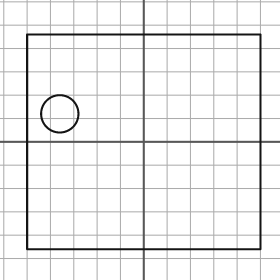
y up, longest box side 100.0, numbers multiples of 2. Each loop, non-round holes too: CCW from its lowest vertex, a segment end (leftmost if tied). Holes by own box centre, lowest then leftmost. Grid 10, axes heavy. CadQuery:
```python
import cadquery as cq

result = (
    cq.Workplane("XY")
    .moveTo(-50.0, -46.0)
    .lineTo(50.0, -46.0)
    .lineTo(50.0, 46.0)
    .lineTo(-50.0, 46.0)
    .close()
    .moveTo(-36.0, 12.0)
    .circle(8.0)
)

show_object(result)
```